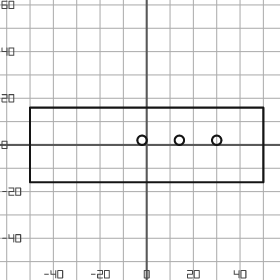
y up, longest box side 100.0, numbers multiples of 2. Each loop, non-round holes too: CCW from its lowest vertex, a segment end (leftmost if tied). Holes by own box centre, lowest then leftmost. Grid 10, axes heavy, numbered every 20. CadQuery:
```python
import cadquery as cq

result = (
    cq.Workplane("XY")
    .moveTo(-50.0, -16.0)
    .lineTo(50.0, -16.0)
    .lineTo(50.0, 16.0)
    .lineTo(-50.0, 16.0)
    .close()
    .moveTo(-2.0, 2.0)
    .circle(2.0)
    .moveTo(14.0, 2.0)
    .circle(2.0)
    .moveTo(30.0, 2.0)
    .circle(2.0)
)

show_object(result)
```